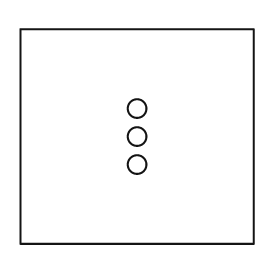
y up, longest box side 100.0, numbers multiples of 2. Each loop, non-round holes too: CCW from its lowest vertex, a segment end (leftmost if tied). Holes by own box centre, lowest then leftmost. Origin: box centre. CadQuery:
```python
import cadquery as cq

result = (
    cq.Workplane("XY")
    .moveTo(-50.0, -46.0)
    .lineTo(50.0, -46.0)
    .lineTo(50.0, 46.0)
    .lineTo(-50.0, 46.0)
    .close()
    .moveTo(0.0, -12.0)
    .circle(4.0)
    .moveTo(0.0, 0.0)
    .circle(4.0)
    .moveTo(0.0, 12.0)
    .circle(4.0)
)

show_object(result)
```